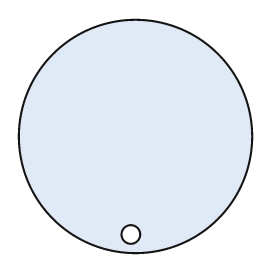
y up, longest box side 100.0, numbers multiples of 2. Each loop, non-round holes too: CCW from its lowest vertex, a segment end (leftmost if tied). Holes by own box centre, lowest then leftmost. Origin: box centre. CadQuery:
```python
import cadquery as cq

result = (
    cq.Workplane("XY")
    .moveTo(0.0, 0.0)
    .circle(50.0)
    .moveTo(-2.0, -42.0)
    .circle(4.0)
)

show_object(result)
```